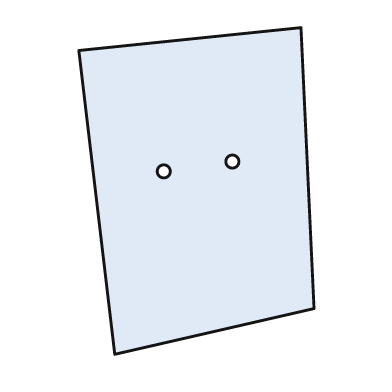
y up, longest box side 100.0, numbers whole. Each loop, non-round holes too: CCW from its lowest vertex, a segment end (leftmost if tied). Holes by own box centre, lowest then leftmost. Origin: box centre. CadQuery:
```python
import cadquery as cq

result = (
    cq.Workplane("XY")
    .moveTo(-25.0, -50.0)
    .lineTo(36.0, -36.0)
    .lineTo(32.0, 50.0)
    .lineTo(-36.0, 43.0)
    .close()
    .moveTo(-10.0, 6.0)
    .circle(2.0)
    .moveTo(11.0, 9.0)
    .circle(2.0)
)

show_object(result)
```